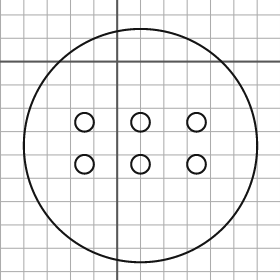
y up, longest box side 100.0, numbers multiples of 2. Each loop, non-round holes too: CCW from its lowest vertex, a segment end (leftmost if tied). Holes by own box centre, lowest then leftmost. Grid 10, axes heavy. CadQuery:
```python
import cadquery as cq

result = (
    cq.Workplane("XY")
    .moveTo(10.0, -36.0)
    .circle(50.0)
    .moveTo(-14.0, -44.0)
    .circle(4.0)
    .moveTo(10.0, -44.0)
    .circle(4.0)
    .moveTo(34.0, -44.0)
    .circle(4.0)
    .moveTo(-14.0, -26.0)
    .circle(4.0)
    .moveTo(10.0, -26.0)
    .circle(4.0)
    .moveTo(34.0, -26.0)
    .circle(4.0)
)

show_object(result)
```